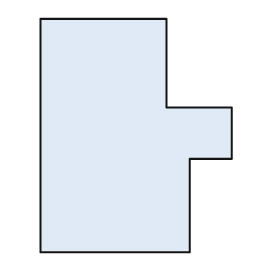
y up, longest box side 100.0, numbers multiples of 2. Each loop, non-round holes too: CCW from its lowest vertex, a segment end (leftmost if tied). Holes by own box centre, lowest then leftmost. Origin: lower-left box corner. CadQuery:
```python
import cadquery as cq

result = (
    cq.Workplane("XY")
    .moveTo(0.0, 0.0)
    .lineTo(64.0, 0.0)
    .lineTo(64.0, 40.0)
    .lineTo(82.0, 40.0)
    .lineTo(82.0, 62.0)
    .lineTo(54.0, 62.0)
    .lineTo(54.0, 100.0)
    .lineTo(0.0, 100.0)
    .close()
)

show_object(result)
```